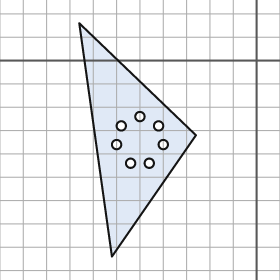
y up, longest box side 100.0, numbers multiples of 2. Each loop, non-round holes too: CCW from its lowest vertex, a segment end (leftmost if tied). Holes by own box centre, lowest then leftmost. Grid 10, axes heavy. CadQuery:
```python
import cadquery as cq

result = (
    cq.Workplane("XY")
    .moveTo(-62.0, -84.0)
    .lineTo(-26.0, -32.0)
    .lineTo(-76.0, 16.0)
    .close()
    .moveTo(-54.0, -44.0)
    .circle(2.0)
    .moveTo(-46.0, -44.0)
    .circle(2.0)
    .moveTo(-60.0, -36.0)
    .circle(2.0)
    .moveTo(-40.0, -36.0)
    .circle(2.0)
    .moveTo(-58.0, -28.0)
    .circle(2.0)
    .moveTo(-42.0, -28.0)
    .circle(2.0)
    .moveTo(-50.0, -24.0)
    .circle(2.0)
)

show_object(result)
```